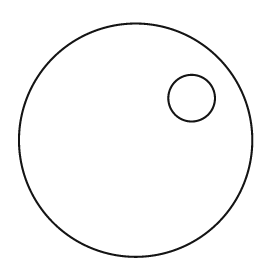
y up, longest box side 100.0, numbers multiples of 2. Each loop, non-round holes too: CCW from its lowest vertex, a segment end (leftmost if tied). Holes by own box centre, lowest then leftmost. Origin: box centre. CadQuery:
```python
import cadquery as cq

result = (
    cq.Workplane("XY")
    .moveTo(0.0, 0.0)
    .circle(50.0)
    .moveTo(24.0, 18.0)
    .circle(10.0)
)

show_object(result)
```